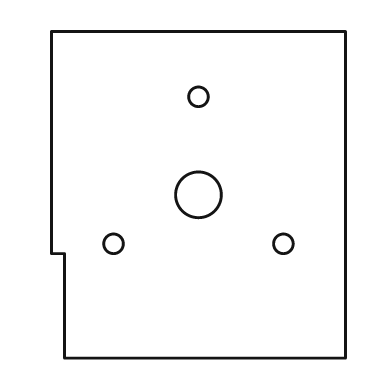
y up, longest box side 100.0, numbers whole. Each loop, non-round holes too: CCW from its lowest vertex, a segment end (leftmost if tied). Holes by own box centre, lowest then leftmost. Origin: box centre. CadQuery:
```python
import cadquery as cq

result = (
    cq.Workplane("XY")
    .moveTo(-41.0, -50.0)
    .lineTo(45.0, -50.0)
    .lineTo(45.0, 50.0)
    .lineTo(-45.0, 50.0)
    .lineTo(-45.0, -18.0)
    .lineTo(-41.0, -18.0)
    .close()
    .moveTo(-26.0, -15.0)
    .circle(3.0)
    .moveTo(26.0, -15.0)
    .circle(3.0)
    .moveTo(0.0, 0.0)
    .circle(7.0)
    .moveTo(0.0, 30.0)
    .circle(3.0)
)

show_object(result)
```